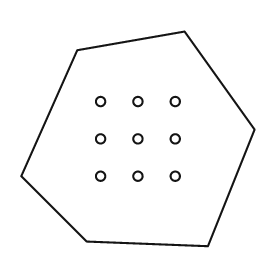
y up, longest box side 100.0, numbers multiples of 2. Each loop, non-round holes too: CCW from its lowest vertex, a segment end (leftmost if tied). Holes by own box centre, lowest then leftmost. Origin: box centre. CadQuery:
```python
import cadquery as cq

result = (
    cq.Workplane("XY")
    .moveTo(30.0, -46.0)
    .lineTo(50.0, 4.0)
    .lineTo(20.0, 46.0)
    .lineTo(-26.0, 38.0)
    .lineTo(-50.0, -16.0)
    .lineTo(-22.0, -44.0)
    .close()
    .moveTo(-16.0, -16.0)
    .circle(2.0)
    .moveTo(0.0, -16.0)
    .circle(2.0)
    .moveTo(16.0, -16.0)
    .circle(2.0)
    .moveTo(-16.0, 0.0)
    .circle(2.0)
    .moveTo(0.0, 0.0)
    .circle(2.0)
    .moveTo(16.0, 0.0)
    .circle(2.0)
    .moveTo(-16.0, 16.0)
    .circle(2.0)
    .moveTo(0.0, 16.0)
    .circle(2.0)
    .moveTo(16.0, 16.0)
    .circle(2.0)
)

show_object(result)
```